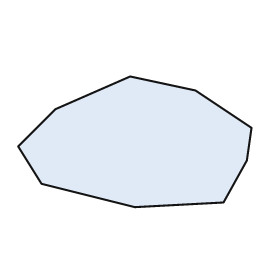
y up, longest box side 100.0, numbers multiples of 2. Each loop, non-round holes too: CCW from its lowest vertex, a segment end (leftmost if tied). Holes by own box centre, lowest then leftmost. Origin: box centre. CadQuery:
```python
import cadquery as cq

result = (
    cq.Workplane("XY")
    .moveTo(0.0, -28.0)
    .lineTo(38.0, -26.0)
    .lineTo(48.0, -8.0)
    .lineTo(50.0, 6.0)
    .lineTo(26.0, 22.0)
    .lineTo(-2.0, 28.0)
    .lineTo(-34.0, 14.0)
    .lineTo(-50.0, -2.0)
    .lineTo(-40.0, -18.0)
    .close()
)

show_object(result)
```